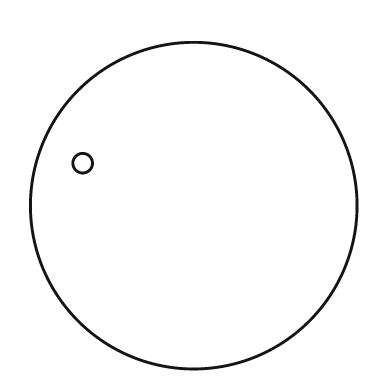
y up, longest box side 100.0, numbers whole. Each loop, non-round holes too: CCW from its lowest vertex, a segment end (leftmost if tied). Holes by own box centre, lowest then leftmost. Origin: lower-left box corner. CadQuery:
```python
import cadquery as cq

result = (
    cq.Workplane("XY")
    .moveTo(50.0, 50.0)
    .circle(50.0)
    .moveTo(16.0, 63.0)
    .circle(3.0)
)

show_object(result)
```